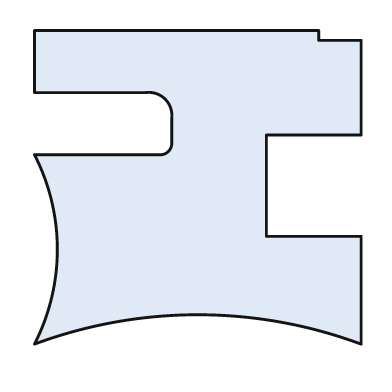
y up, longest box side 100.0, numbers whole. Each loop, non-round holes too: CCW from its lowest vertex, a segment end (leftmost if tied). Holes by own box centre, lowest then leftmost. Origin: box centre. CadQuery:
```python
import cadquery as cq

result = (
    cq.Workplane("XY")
    .moveTo(-50.0, -48.0)
    .threePointArc((0.0, -39.0), (50.0, -48.0))
    .lineTo(50.0, -15.0)
    .lineTo(21.0, -15.0)
    .lineTo(21.0, 16.0)
    .lineTo(50.0, 16.0)
    .lineTo(50.0, 45.0)
    .lineTo(37.0, 45.0)
    .lineTo(37.0, 48.0)
    .lineTo(-50.0, 48.0)
    .lineTo(-50.0, 29.0)
    .lineTo(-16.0, 29.0)
    .threePointArc((-10.0, 27.0), (-8.0, 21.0))
    .lineTo(-8.0, 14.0)
    .threePointArc((-9.0, 11.0), (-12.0, 10.0))
    .lineTo(-50.0, 10.0)
    .threePointArc((-43.0, -19.0), (-50.0, -48.0))
    .close()
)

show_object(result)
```